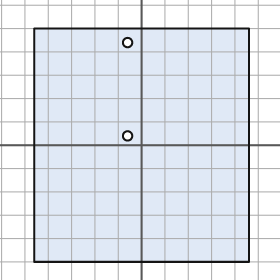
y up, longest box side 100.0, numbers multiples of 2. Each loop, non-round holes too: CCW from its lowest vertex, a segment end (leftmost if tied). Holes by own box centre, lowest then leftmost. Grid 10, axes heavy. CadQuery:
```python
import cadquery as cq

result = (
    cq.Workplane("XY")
    .moveTo(-46.0, -50.0)
    .lineTo(46.0, -50.0)
    .lineTo(46.0, 50.0)
    .lineTo(-46.0, 50.0)
    .close()
    .moveTo(-6.0, 4.0)
    .circle(2.0)
    .moveTo(-6.0, 44.0)
    .circle(2.0)
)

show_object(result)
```